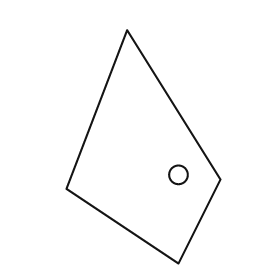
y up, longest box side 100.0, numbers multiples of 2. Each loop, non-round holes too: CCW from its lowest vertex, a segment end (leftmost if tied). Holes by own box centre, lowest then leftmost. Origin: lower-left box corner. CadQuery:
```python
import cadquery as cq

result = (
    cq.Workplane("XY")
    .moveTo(48.0, 0.0)
    .lineTo(66.0, 36.0)
    .lineTo(26.0, 100.0)
    .lineTo(0.0, 32.0)
    .close()
    .moveTo(48.0, 38.0)
    .circle(4.0)
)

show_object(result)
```